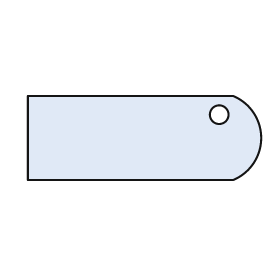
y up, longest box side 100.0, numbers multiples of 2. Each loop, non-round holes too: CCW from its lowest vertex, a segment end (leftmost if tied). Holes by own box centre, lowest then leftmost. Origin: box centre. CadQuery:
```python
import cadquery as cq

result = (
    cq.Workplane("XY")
    .moveTo(-50.0, -18.0)
    .lineTo(38.0, -18.0)
    .threePointArc((50.0, 0.0), (38.0, 18.0))
    .lineTo(-50.0, 18.0)
    .close()
    .moveTo(32.0, 10.0)
    .circle(4.0)
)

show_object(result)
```